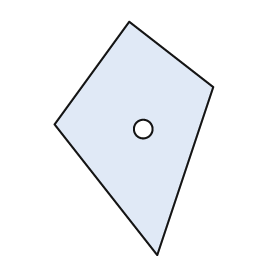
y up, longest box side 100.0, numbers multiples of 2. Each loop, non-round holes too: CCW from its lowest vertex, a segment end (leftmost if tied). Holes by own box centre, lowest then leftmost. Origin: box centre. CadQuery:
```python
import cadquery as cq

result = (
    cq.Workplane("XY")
    .moveTo(10.0, -50.0)
    .lineTo(34.0, 22.0)
    .lineTo(-2.0, 50.0)
    .lineTo(-34.0, 6.0)
    .close()
    .moveTo(4.0, 4.0)
    .circle(4.0)
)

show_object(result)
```